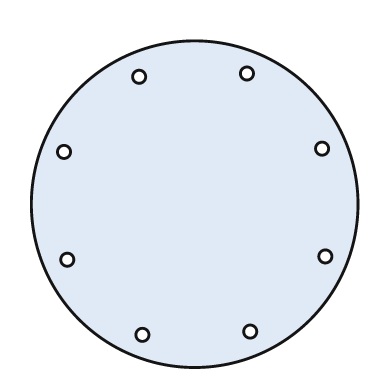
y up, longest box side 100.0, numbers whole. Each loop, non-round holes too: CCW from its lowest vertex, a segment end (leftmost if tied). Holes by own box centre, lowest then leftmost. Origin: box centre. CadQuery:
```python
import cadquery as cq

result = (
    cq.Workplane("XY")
    .moveTo(0.0, 0.0)
    .circle(50.0)
    .moveTo(-16.0, -40.0)
    .circle(2.0)
    .moveTo(17.0, -39.0)
    .circle(2.0)
    .moveTo(-39.0, -17.0)
    .circle(2.0)
    .moveTo(40.0, -16.0)
    .circle(2.0)
    .moveTo(-40.0, 16.0)
    .circle(2.0)
    .moveTo(39.0, 17.0)
    .circle(2.0)
    .moveTo(-17.0, 39.0)
    .circle(2.0)
    .moveTo(16.0, 40.0)
    .circle(2.0)
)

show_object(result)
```